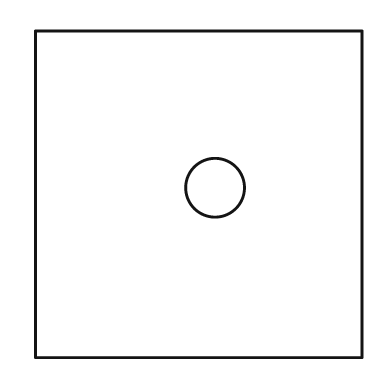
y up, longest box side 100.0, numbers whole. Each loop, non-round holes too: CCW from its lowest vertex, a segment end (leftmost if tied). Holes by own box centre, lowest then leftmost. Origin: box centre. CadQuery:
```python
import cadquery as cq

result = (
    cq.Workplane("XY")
    .moveTo(-50.0, -50.0)
    .lineTo(50.0, -50.0)
    .lineTo(50.0, 50.0)
    .lineTo(-50.0, 50.0)
    .close()
    .moveTo(5.0, 2.0)
    .circle(9.0)
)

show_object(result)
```